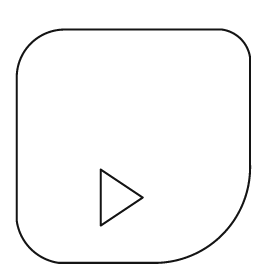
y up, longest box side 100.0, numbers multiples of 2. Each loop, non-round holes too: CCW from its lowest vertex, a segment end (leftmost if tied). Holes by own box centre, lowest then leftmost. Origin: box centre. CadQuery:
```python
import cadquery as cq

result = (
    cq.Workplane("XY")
    .moveTo(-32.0, -50.0)
    .lineTo(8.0, -50.0)
    .threePointArc((38.0, -38.0), (50.0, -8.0))
    .lineTo(50.0, 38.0)
    .threePointArc((46.0, 46.0), (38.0, 50.0))
    .lineTo(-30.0, 50.0)
    .threePointArc((-44.0, 44.0), (-50.0, 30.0))
    .lineTo(-50.0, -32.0)
    .threePointArc((-44.0, -44.0), (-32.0, -50.0))
    .close()
    .moveTo(-14.0, -34.0)
    .lineTo(4.0, -22.0)
    .lineTo(-14.0, -10.0)
    .close()
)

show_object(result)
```